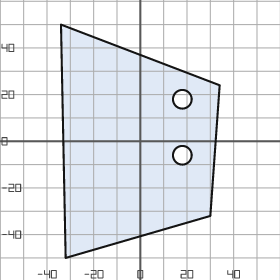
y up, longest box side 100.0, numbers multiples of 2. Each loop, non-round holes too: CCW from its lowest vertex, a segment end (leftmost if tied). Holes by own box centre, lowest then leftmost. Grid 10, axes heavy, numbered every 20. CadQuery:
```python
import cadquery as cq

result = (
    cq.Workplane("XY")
    .moveTo(-32.0, -50.0)
    .lineTo(30.0, -32.0)
    .lineTo(34.0, 24.0)
    .lineTo(-34.0, 50.0)
    .close()
    .moveTo(18.0, -6.0)
    .circle(4.0)
    .moveTo(18.0, 18.0)
    .circle(4.0)
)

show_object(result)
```